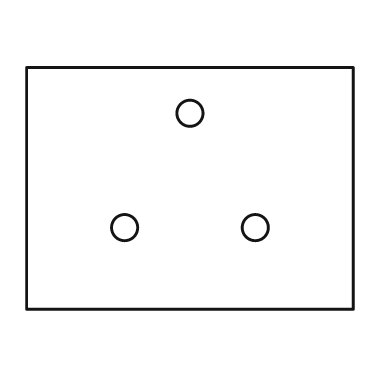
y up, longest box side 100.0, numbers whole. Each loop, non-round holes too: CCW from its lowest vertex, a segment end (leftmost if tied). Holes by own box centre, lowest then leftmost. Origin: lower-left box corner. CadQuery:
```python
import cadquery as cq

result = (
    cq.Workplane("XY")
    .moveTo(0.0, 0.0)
    .lineTo(100.0, 0.0)
    .lineTo(100.0, 74.0)
    .lineTo(0.0, 74.0)
    .close()
    .moveTo(30.0, 25.0)
    .circle(4.0)
    .moveTo(70.0, 25.0)
    .circle(4.0)
    .moveTo(50.0, 60.0)
    .circle(4.0)
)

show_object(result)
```